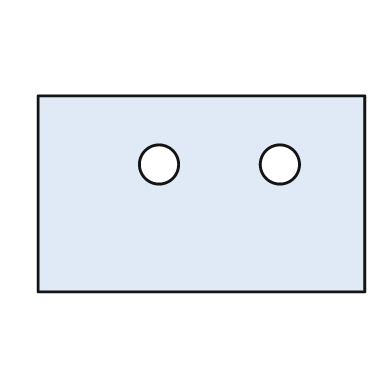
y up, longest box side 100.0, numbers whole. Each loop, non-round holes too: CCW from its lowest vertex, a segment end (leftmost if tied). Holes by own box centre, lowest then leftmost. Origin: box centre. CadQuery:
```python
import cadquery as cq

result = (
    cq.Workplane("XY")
    .moveTo(-50.0, -30.0)
    .lineTo(50.0, -30.0)
    .lineTo(50.0, 30.0)
    .lineTo(-50.0, 30.0)
    .close()
    .moveTo(-13.0, 9.0)
    .circle(6.0)
    .moveTo(24.0, 9.0)
    .circle(6.0)
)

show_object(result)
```